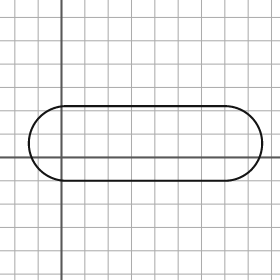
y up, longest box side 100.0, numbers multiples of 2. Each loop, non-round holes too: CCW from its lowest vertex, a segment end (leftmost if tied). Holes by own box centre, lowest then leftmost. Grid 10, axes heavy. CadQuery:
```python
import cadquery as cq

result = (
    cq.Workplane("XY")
    .moveTo(2.0, -10.0)
    .lineTo(70.0, -10.0)
    .threePointArc((86.0, 6.0), (70.0, 22.0))
    .lineTo(2.0, 22.0)
    .threePointArc((-14.0, 6.0), (2.0, -10.0))
    .close()
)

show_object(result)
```